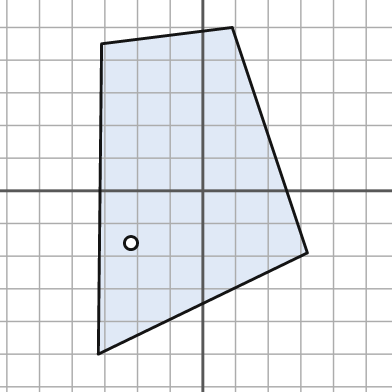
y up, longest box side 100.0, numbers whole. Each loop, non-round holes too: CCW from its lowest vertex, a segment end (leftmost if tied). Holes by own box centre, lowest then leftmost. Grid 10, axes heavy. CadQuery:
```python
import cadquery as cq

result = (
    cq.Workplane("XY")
    .moveTo(-32.0, -50.0)
    .lineTo(32.0, -19.0)
    .lineTo(9.0, 50.0)
    .lineTo(-31.0, 45.0)
    .close()
    .moveTo(-22.0, -16.0)
    .circle(2.0)
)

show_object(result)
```